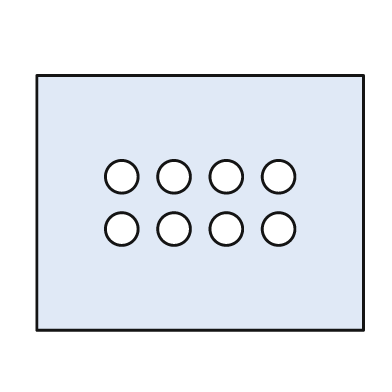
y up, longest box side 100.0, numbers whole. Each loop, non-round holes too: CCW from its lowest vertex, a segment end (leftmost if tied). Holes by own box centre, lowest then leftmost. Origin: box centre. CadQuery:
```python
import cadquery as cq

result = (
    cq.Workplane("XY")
    .moveTo(-50.0, -39.0)
    .lineTo(50.0, -39.0)
    .lineTo(50.0, 39.0)
    .lineTo(-50.0, 39.0)
    .close()
    .moveTo(-24.0, -8.0)
    .circle(5.0)
    .moveTo(-8.0, -8.0)
    .circle(5.0)
    .moveTo(8.0, -8.0)
    .circle(5.0)
    .moveTo(24.0, -8.0)
    .circle(5.0)
    .moveTo(-24.0, 8.0)
    .circle(5.0)
    .moveTo(-8.0, 8.0)
    .circle(5.0)
    .moveTo(8.0, 8.0)
    .circle(5.0)
    .moveTo(24.0, 8.0)
    .circle(5.0)
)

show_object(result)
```